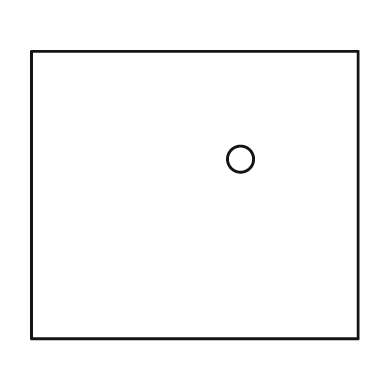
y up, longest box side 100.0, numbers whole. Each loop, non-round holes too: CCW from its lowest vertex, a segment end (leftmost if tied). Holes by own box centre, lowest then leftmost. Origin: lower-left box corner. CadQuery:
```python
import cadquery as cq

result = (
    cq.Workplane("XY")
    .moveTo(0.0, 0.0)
    .lineTo(100.0, 0.0)
    .lineTo(100.0, 88.0)
    .lineTo(0.0, 88.0)
    .close()
    .moveTo(64.0, 55.0)
    .circle(4.0)
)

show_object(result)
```